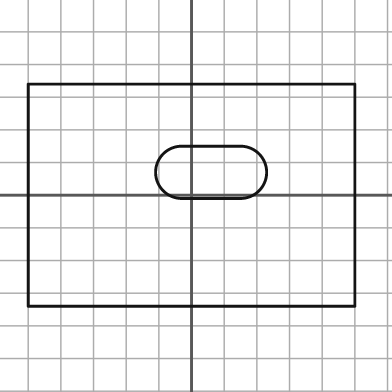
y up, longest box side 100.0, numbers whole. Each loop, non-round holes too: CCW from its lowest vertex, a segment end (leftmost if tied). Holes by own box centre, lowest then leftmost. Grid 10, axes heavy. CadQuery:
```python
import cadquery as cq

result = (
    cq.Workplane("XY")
    .moveTo(-50.0, -34.0)
    .lineTo(50.0, -34.0)
    .lineTo(50.0, 34.0)
    .lineTo(-50.0, 34.0)
    .close()
    .moveTo(-3.0, -1.0)
    .lineTo(15.0, -1.0)
    .threePointArc((23.0, 7.0), (15.0, 15.0))
    .lineTo(-3.0, 15.0)
    .threePointArc((-11.0, 7.0), (-3.0, -1.0))
    .close()
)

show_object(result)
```